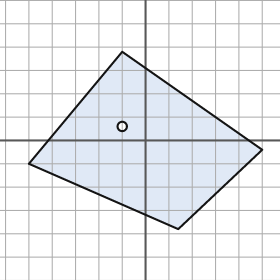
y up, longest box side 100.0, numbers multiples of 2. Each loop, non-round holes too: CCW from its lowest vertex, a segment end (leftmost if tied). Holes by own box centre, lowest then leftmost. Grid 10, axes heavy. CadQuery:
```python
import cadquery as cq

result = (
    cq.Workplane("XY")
    .moveTo(14.0, -38.0)
    .lineTo(50.0, -4.0)
    .lineTo(-10.0, 38.0)
    .lineTo(-50.0, -10.0)
    .close()
    .moveTo(-10.0, 6.0)
    .circle(2.0)
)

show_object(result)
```